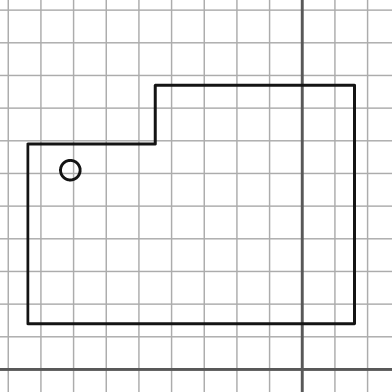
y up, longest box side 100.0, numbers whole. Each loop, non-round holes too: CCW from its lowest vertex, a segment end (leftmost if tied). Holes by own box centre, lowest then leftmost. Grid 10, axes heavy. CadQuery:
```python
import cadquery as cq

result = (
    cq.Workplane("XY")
    .moveTo(-84.0, 14.0)
    .lineTo(16.0, 14.0)
    .lineTo(16.0, 87.0)
    .lineTo(-45.0, 87.0)
    .lineTo(-45.0, 69.0)
    .lineTo(-84.0, 69.0)
    .close()
    .moveTo(-71.0, 61.0)
    .circle(3.0)
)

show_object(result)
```